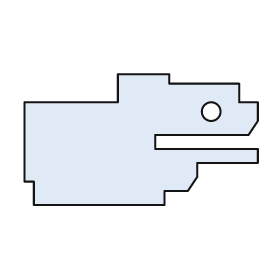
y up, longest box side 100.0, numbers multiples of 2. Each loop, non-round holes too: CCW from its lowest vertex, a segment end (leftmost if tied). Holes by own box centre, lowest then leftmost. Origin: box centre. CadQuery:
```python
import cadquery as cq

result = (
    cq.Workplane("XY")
    .moveTo(-46.0, -28.0)
    .lineTo(10.0, -28.0)
    .lineTo(10.0, -22.0)
    .lineTo(20.0, -22.0)
    .lineTo(24.0, -16.0)
    .lineTo(24.0, -10.0)
    .lineTo(50.0, -10.0)
    .lineTo(50.0, -4.0)
    .lineTo(6.0, -4.0)
    .lineTo(6.0, 2.0)
    .lineTo(46.0, 2.0)
    .lineTo(50.0, 8.0)
    .lineTo(50.0, 16.0)
    .lineTo(42.0, 16.0)
    .lineTo(42.0, 24.0)
    .lineTo(12.0, 24.0)
    .lineTo(12.0, 28.0)
    .lineTo(-10.0, 28.0)
    .lineTo(-10.0, 16.0)
    .lineTo(-50.0, 16.0)
    .lineTo(-50.0, -18.0)
    .lineTo(-46.0, -18.0)
    .close()
    .moveTo(30.0, 12.0)
    .circle(4.0)
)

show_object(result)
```